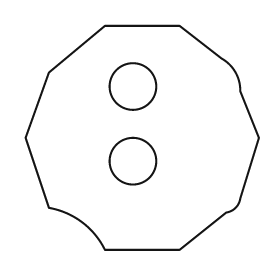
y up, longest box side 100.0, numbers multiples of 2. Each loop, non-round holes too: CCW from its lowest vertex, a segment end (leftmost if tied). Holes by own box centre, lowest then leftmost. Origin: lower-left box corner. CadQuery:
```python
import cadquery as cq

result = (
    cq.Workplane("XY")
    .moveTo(34.0, 0.0)
    .lineTo(66.0, 0.0)
    .lineTo(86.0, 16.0)
    .threePointArc((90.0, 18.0), (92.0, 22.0))
    .lineTo(100.0, 48.0)
    .lineTo(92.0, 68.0)
    .threePointArc((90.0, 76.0), (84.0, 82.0))
    .lineTo(66.0, 96.0)
    .lineTo(34.0, 96.0)
    .lineTo(10.0, 76.0)
    .lineTo(0.0, 48.0)
    .lineTo(10.0, 18.0)
    .threePointArc((24.0, 12.0), (34.0, 0.0))
    .close()
    .moveTo(46.0, 38.0)
    .circle(10.0)
    .moveTo(46.0, 70.0)
    .circle(10.0)
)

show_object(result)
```